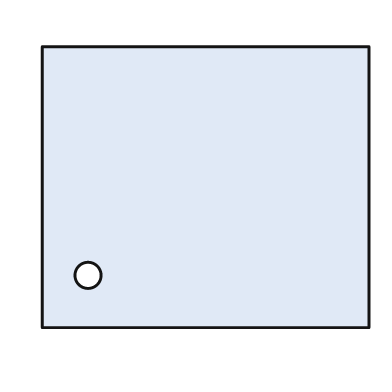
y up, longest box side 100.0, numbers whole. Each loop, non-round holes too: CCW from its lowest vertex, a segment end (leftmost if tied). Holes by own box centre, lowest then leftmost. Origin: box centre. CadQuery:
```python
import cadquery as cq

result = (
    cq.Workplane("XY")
    .moveTo(-50.0, -43.0)
    .lineTo(50.0, -43.0)
    .lineTo(50.0, 43.0)
    .lineTo(-50.0, 43.0)
    .close()
    .moveTo(-36.0, -27.0)
    .circle(4.0)
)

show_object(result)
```